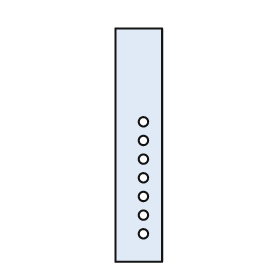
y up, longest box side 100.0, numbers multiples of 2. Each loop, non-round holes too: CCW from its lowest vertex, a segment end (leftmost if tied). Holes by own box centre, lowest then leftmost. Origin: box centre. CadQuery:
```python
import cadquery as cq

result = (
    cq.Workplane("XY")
    .moveTo(-10.0, -50.0)
    .lineTo(10.0, -50.0)
    .lineTo(10.0, 50.0)
    .lineTo(-10.0, 50.0)
    .close()
    .moveTo(2.0, -38.0)
    .circle(2.0)
    .moveTo(2.0, -30.0)
    .circle(2.0)
    .moveTo(2.0, -22.0)
    .circle(2.0)
    .moveTo(2.0, -14.0)
    .circle(2.0)
    .moveTo(2.0, -6.0)
    .circle(2.0)
    .moveTo(2.0, 2.0)
    .circle(2.0)
    .moveTo(2.0, 10.0)
    .circle(2.0)
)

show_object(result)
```